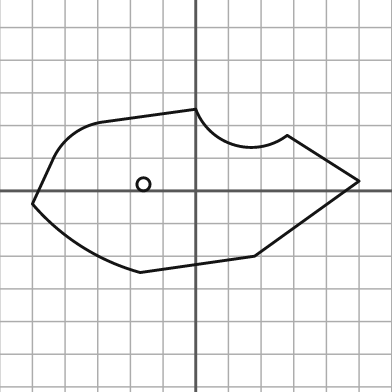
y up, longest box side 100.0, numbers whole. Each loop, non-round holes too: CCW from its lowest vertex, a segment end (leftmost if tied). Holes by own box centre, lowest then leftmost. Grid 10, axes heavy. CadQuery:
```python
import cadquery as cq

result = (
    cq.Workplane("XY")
    .moveTo(-17.0, -25.0)
    .lineTo(18.0, -20.0)
    .lineTo(50.0, 3.0)
    .lineTo(28.0, 17.0)
    .threePointArc((12.0, 14.0), (0.0, 25.0))
    .lineTo(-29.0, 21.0)
    .threePointArc((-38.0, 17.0), (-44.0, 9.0))
    .lineTo(-50.0, -4.0)
    .threePointArc((-35.0, -17.0), (-17.0, -25.0))
    .close()
    .moveTo(-16.0, 2.0)
    .circle(2.0)
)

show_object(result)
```